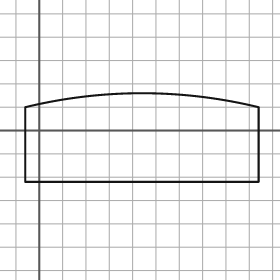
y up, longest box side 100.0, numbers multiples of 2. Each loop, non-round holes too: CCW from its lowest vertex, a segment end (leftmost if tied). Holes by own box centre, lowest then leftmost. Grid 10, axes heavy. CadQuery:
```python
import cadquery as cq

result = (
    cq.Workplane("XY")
    .moveTo(-6.0, -22.0)
    .lineTo(94.0, -22.0)
    .lineTo(94.0, 10.0)
    .threePointArc((44.0, 16.0), (-6.0, 10.0))
    .close()
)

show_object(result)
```